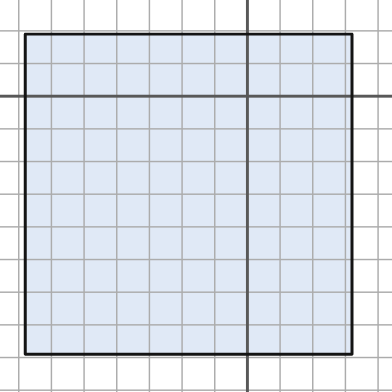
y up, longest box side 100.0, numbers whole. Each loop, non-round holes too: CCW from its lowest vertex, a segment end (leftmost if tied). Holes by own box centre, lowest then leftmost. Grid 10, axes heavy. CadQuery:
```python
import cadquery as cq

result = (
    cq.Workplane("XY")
    .moveTo(-68.0, -79.0)
    .lineTo(32.0, -79.0)
    .lineTo(32.0, 19.0)
    .lineTo(-68.0, 19.0)
    .close()
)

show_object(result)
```